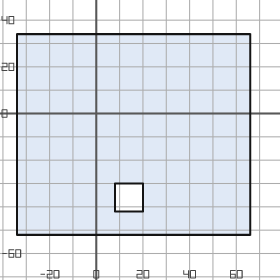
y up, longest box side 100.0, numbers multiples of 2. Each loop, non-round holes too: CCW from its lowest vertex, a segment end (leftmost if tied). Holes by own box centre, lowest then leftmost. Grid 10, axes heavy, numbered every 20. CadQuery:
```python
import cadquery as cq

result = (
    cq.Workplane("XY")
    .moveTo(-34.0, -52.0)
    .lineTo(66.0, -52.0)
    .lineTo(66.0, 34.0)
    .lineTo(-34.0, 34.0)
    .close()
    .moveTo(8.0, -42.0)
    .lineTo(20.0, -42.0)
    .lineTo(20.0, -30.0)
    .lineTo(8.0, -30.0)
    .close()
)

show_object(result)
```